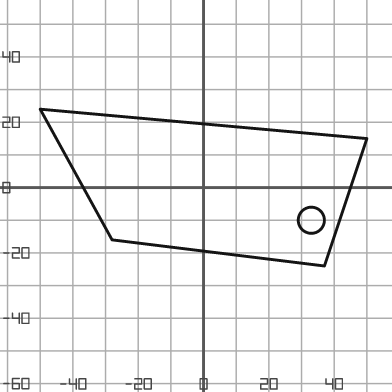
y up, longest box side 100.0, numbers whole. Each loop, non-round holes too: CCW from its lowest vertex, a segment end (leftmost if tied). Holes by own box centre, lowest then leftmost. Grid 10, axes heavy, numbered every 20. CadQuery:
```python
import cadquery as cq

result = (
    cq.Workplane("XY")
    .moveTo(37.0, -24.0)
    .lineTo(50.0, 15.0)
    .lineTo(-50.0, 24.0)
    .lineTo(-28.0, -16.0)
    .close()
    .moveTo(33.0, -10.0)
    .circle(4.0)
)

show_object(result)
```